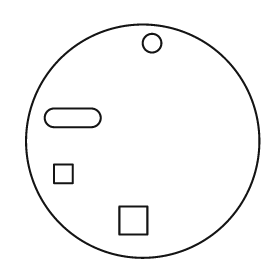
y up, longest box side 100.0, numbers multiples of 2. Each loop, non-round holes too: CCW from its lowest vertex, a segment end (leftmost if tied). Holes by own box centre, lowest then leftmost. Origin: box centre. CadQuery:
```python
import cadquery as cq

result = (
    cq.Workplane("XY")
    .moveTo(0.0, 0.0)
    .circle(50.0)
    .moveTo(-10.0, -40.0)
    .lineTo(2.0, -40.0)
    .lineTo(2.0, -28.0)
    .lineTo(-10.0, -28.0)
    .close()
    .moveTo(-38.0, -18.0)
    .lineTo(-30.0, -18.0)
    .lineTo(-30.0, -10.0)
    .lineTo(-38.0, -10.0)
    .close()
    .moveTo(-38.0, 6.0)
    .lineTo(-22.0, 6.0)
    .threePointArc((-18.0, 10.0), (-22.0, 14.0))
    .lineTo(-38.0, 14.0)
    .threePointArc((-42.0, 10.0), (-38.0, 6.0))
    .close()
    .moveTo(4.0, 42.0)
    .circle(4.0)
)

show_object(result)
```